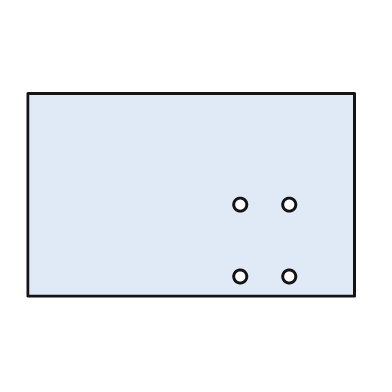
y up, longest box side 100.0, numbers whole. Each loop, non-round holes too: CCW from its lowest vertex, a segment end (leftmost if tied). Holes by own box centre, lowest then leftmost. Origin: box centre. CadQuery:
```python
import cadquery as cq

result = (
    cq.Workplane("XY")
    .moveTo(-50.0, -31.0)
    .lineTo(50.0, -31.0)
    .lineTo(50.0, 31.0)
    .lineTo(-50.0, 31.0)
    .close()
    .moveTo(15.0, -25.0)
    .circle(2.0)
    .moveTo(30.0, -25.0)
    .circle(2.0)
    .moveTo(15.0, -3.0)
    .circle(2.0)
    .moveTo(30.0, -3.0)
    .circle(2.0)
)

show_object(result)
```